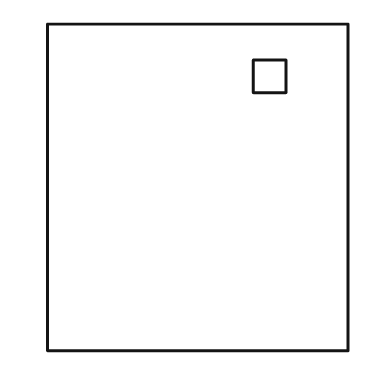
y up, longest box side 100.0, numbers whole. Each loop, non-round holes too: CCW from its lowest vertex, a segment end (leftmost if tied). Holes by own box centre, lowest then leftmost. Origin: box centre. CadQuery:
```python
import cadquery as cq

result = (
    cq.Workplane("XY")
    .moveTo(-46.0, -50.0)
    .lineTo(46.0, -50.0)
    .lineTo(46.0, 50.0)
    .lineTo(-46.0, 50.0)
    .close()
    .moveTo(17.0, 29.0)
    .lineTo(27.0, 29.0)
    .lineTo(27.0, 39.0)
    .lineTo(17.0, 39.0)
    .close()
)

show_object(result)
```